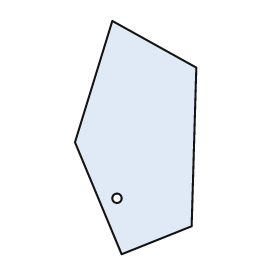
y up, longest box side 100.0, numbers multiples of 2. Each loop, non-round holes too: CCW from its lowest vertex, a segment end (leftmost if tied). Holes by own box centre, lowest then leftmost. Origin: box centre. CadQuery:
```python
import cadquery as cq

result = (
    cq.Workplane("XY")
    .moveTo(-6.0, -50.0)
    .lineTo(24.0, -38.0)
    .lineTo(26.0, 30.0)
    .lineTo(-10.0, 50.0)
    .lineTo(-26.0, -2.0)
    .close()
    .moveTo(-8.0, -26.0)
    .circle(2.0)
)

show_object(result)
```